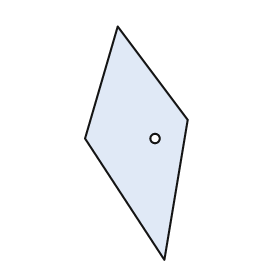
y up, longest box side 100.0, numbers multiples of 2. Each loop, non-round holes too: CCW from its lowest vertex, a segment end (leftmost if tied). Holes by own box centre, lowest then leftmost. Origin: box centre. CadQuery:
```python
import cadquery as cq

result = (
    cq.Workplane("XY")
    .moveTo(12.0, -50.0)
    .lineTo(22.0, 10.0)
    .lineTo(-8.0, 50.0)
    .lineTo(-22.0, 2.0)
    .close()
    .moveTo(8.0, 2.0)
    .circle(2.0)
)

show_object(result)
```